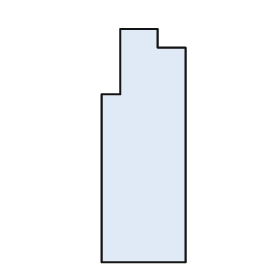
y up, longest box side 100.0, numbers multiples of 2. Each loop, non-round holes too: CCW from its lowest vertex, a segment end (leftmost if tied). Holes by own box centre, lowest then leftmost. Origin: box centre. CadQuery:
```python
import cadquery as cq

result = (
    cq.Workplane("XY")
    .moveTo(-18.0, -50.0)
    .lineTo(18.0, -50.0)
    .lineTo(18.0, 42.0)
    .lineTo(6.0, 42.0)
    .lineTo(6.0, 50.0)
    .lineTo(-10.0, 50.0)
    .lineTo(-10.0, 22.0)
    .lineTo(-18.0, 22.0)
    .close()
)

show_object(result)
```